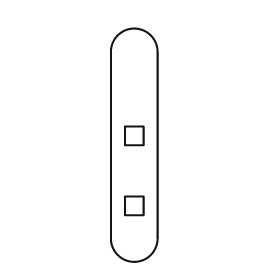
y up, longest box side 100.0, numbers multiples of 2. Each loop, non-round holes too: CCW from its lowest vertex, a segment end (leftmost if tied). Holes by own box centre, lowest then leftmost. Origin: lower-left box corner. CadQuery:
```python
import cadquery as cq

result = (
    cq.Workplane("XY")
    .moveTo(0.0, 10.0)
    .threePointArc((10.0, 0.0), (20.0, 10.0))
    .lineTo(20.0, 90.0)
    .threePointArc((10.0, 100.0), (0.0, 90.0))
    .close()
    .moveTo(6.0, 20.0)
    .lineTo(14.0, 20.0)
    .lineTo(14.0, 28.0)
    .lineTo(6.0, 28.0)
    .close()
    .moveTo(6.0, 50.0)
    .lineTo(14.0, 50.0)
    .lineTo(14.0, 58.0)
    .lineTo(6.0, 58.0)
    .close()
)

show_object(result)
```